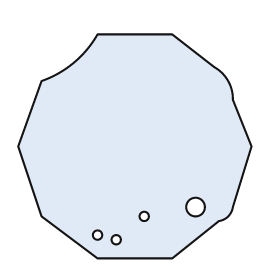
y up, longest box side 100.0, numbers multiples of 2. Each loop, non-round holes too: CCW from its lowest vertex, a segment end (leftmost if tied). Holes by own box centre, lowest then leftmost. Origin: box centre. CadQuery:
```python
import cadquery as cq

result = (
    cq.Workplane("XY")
    .moveTo(-16.0, -48.0)
    .lineTo(16.0, -48.0)
    .lineTo(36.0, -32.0)
    .threePointArc((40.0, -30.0), (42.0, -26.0))
    .lineTo(50.0, 0.0)
    .lineTo(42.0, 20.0)
    .threePointArc((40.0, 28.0), (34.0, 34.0))
    .lineTo(16.0, 48.0)
    .lineTo(-16.0, 48.0)
    .threePointArc((-26.0, 36.0), (-40.0, 28.0))
    .lineTo(-50.0, 0.0)
    .lineTo(-40.0, -30.0)
    .close()
    .moveTo(-8.0, -40.0)
    .circle(2.0)
    .moveTo(-16.0, -38.0)
    .circle(2.0)
    .moveTo(4.0, -30.0)
    .circle(2.0)
    .moveTo(26.0, -26.0)
    .circle(4.0)
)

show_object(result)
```